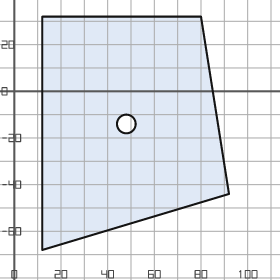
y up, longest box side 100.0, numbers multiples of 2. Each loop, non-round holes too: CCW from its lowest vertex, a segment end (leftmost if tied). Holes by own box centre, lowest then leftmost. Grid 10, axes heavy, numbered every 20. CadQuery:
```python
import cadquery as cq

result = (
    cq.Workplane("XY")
    .moveTo(12.0, -68.0)
    .lineTo(92.0, -44.0)
    .lineTo(80.0, 32.0)
    .lineTo(12.0, 32.0)
    .close()
    .moveTo(48.0, -14.0)
    .circle(4.0)
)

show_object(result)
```